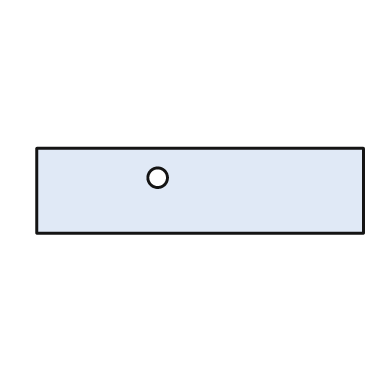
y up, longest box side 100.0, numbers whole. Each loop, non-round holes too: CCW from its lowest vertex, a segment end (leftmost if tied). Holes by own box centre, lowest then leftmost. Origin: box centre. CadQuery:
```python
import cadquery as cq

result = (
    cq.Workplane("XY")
    .moveTo(-50.0, -13.0)
    .lineTo(50.0, -13.0)
    .lineTo(50.0, 13.0)
    .lineTo(-50.0, 13.0)
    .close()
    .moveTo(-13.0, 4.0)
    .circle(3.0)
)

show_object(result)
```